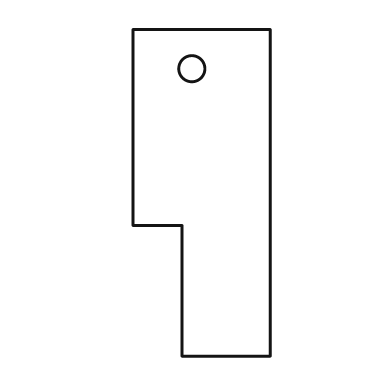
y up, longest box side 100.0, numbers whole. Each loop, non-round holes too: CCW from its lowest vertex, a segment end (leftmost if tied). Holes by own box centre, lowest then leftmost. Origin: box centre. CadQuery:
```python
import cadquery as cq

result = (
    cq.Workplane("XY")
    .moveTo(-6.0, -50.0)
    .lineTo(21.0, -50.0)
    .lineTo(21.0, 50.0)
    .lineTo(-21.0, 50.0)
    .lineTo(-21.0, -10.0)
    .lineTo(-6.0, -10.0)
    .close()
    .moveTo(-3.0, 38.0)
    .circle(4.0)
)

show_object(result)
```